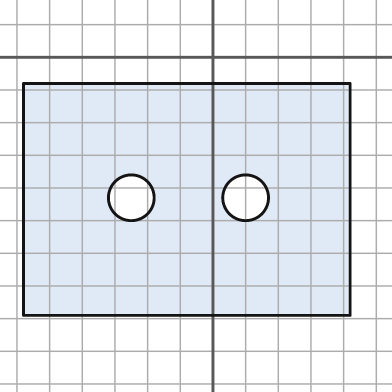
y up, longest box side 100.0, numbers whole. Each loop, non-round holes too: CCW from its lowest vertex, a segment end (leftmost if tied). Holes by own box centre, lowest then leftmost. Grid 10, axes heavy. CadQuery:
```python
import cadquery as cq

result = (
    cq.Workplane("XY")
    .moveTo(-58.0, -79.0)
    .lineTo(42.0, -79.0)
    .lineTo(42.0, -8.0)
    .lineTo(-58.0, -8.0)
    .close()
    .moveTo(-25.0, -43.0)
    .circle(7.0)
    .moveTo(10.0, -43.0)
    .circle(7.0)
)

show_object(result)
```